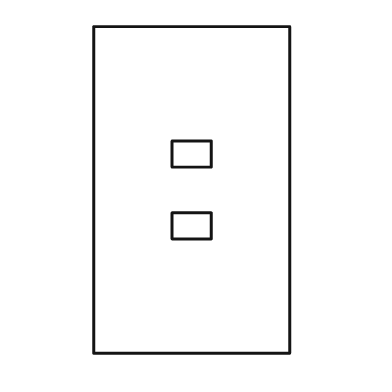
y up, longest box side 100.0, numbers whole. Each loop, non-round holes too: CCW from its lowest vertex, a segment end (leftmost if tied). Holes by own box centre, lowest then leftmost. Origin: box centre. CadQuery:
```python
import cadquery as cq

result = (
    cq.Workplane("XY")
    .moveTo(-30.0, -50.0)
    .lineTo(30.0, -50.0)
    .lineTo(30.0, 50.0)
    .lineTo(-30.0, 50.0)
    .close()
    .moveTo(-6.0, -15.0)
    .lineTo(6.0, -15.0)
    .lineTo(6.0, -7.0)
    .lineTo(-6.0, -7.0)
    .close()
    .moveTo(-6.0, 7.0)
    .lineTo(6.0, 7.0)
    .lineTo(6.0, 15.0)
    .lineTo(-6.0, 15.0)
    .close()
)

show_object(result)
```